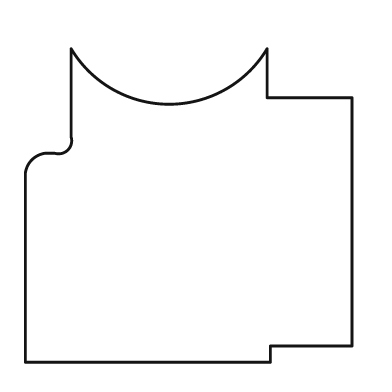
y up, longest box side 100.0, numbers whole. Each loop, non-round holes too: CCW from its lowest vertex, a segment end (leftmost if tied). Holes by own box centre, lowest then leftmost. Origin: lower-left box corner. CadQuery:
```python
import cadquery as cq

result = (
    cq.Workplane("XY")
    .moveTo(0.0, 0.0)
    .lineTo(75.0, 0.0)
    .lineTo(75.0, 5.0)
    .lineTo(100.0, 5.0)
    .lineTo(100.0, 81.0)
    .lineTo(74.0, 81.0)
    .lineTo(74.0, 96.0)
    .threePointArc((44.0, 79.0), (14.0, 96.0))
    .lineTo(14.0, 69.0)
    .threePointArc((13.0, 65.0), (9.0, 64.0))
    .lineTo(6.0, 64.0)
    .threePointArc((2.0, 62.0), (0.0, 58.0))
    .close()
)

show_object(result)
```